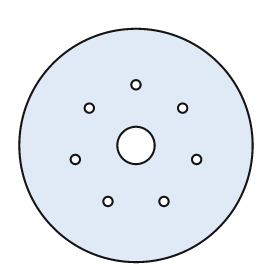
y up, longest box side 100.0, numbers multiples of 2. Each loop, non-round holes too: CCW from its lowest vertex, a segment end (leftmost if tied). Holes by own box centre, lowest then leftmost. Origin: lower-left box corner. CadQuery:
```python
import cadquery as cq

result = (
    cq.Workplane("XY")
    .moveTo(50.0, 50.0)
    .circle(50.0)
    .moveTo(38.0, 26.0)
    .circle(2.0)
    .moveTo(62.0, 26.0)
    .circle(2.0)
    .moveTo(24.0, 44.0)
    .circle(2.0)
    .moveTo(76.0, 44.0)
    .circle(2.0)
    .moveTo(50.0, 50.0)
    .circle(8.0)
    .moveTo(30.0, 66.0)
    .circle(2.0)
    .moveTo(70.0, 66.0)
    .circle(2.0)
    .moveTo(50.0, 76.0)
    .circle(2.0)
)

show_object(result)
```